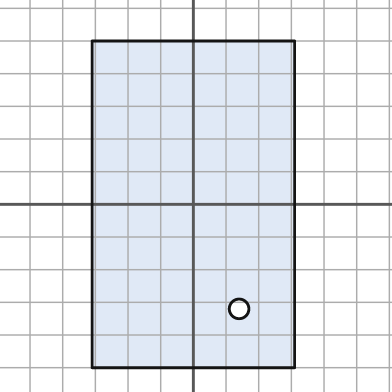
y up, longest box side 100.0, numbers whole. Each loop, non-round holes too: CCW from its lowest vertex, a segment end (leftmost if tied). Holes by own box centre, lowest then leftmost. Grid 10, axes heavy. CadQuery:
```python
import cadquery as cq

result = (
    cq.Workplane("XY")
    .moveTo(-31.0, -50.0)
    .lineTo(31.0, -50.0)
    .lineTo(31.0, 50.0)
    .lineTo(-31.0, 50.0)
    .close()
    .moveTo(14.0, -32.0)
    .circle(3.0)
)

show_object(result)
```